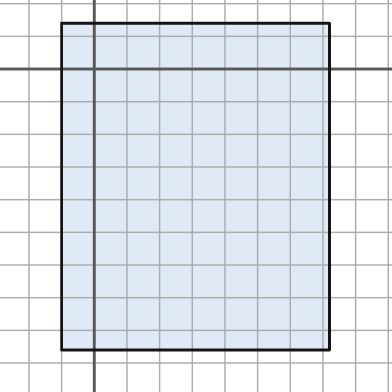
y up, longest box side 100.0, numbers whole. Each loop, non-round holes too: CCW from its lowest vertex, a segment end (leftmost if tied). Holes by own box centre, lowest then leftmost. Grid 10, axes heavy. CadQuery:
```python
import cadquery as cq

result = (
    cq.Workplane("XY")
    .moveTo(-10.0, -86.0)
    .lineTo(72.0, -86.0)
    .lineTo(72.0, 14.0)
    .lineTo(-10.0, 14.0)
    .close()
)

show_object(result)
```